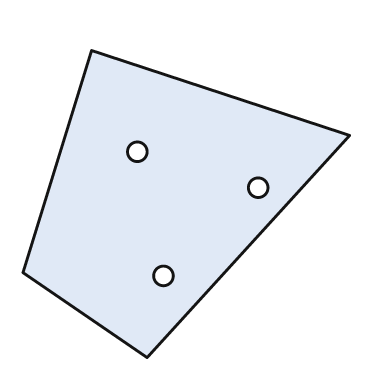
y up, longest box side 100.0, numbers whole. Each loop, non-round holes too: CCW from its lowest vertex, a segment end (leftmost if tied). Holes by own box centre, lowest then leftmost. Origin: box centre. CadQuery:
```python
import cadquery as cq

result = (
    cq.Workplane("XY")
    .moveTo(-12.0, -47.0)
    .lineTo(50.0, 21.0)
    .lineTo(-29.0, 47.0)
    .lineTo(-50.0, -21.0)
    .close()
    .moveTo(-7.0, -22.0)
    .circle(3.0)
    .moveTo(22.0, 5.0)
    .circle(3.0)
    .moveTo(-15.0, 16.0)
    .circle(3.0)
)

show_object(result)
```